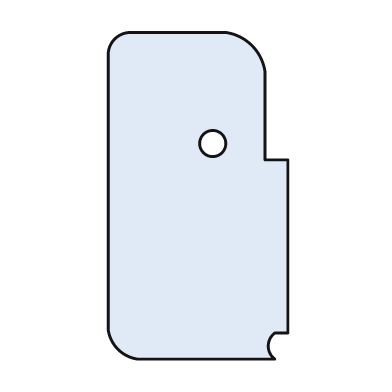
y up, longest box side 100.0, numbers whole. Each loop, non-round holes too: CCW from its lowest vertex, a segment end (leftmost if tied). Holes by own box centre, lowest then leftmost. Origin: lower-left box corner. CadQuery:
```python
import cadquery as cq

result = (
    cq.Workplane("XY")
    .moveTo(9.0, 0.0)
    .lineTo(51.0, 0.0)
    .threePointArc((49.0, 4.0), (51.0, 8.0))
    .lineTo(55.0, 8.0)
    .lineTo(55.0, 61.0)
    .lineTo(48.0, 61.0)
    .lineTo(48.0, 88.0)
    .threePointArc((44.0, 96.0), (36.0, 100.0))
    .lineTo(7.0, 100.0)
    .threePointArc((2.0, 98.0), (0.0, 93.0))
    .lineTo(0.0, 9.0)
    .threePointArc((3.0, 3.0), (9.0, 0.0))
    .close()
    .moveTo(32.0, 66.0)
    .circle(4.0)
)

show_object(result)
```